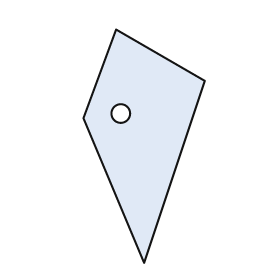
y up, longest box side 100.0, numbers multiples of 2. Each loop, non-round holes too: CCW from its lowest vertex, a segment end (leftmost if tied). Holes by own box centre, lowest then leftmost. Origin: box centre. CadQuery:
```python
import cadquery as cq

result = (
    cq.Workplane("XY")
    .moveTo(0.0, -50.0)
    .lineTo(26.0, 28.0)
    .lineTo(-12.0, 50.0)
    .lineTo(-26.0, 12.0)
    .close()
    .moveTo(-10.0, 14.0)
    .circle(4.0)
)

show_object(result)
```